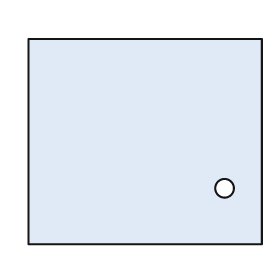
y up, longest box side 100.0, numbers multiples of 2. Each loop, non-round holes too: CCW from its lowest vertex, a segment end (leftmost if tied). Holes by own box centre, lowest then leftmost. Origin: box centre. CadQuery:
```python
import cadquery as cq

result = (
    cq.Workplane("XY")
    .moveTo(-50.0, -44.0)
    .lineTo(50.0, -44.0)
    .lineTo(50.0, 44.0)
    .lineTo(-50.0, 44.0)
    .close()
    .moveTo(34.0, -20.0)
    .circle(4.0)
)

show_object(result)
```